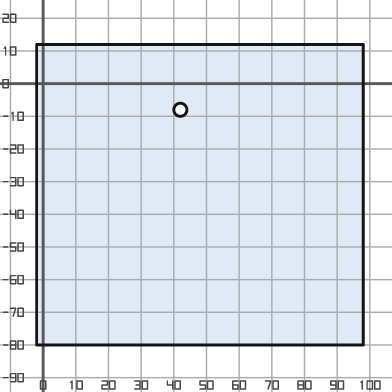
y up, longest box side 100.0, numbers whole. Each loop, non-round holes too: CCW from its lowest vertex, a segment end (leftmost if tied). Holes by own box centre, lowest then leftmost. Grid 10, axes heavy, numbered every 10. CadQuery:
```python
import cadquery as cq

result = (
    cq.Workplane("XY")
    .moveTo(-2.0, -80.0)
    .lineTo(98.0, -80.0)
    .lineTo(98.0, 12.0)
    .lineTo(-2.0, 12.0)
    .close()
    .moveTo(42.0, -8.0)
    .circle(2.0)
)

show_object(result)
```